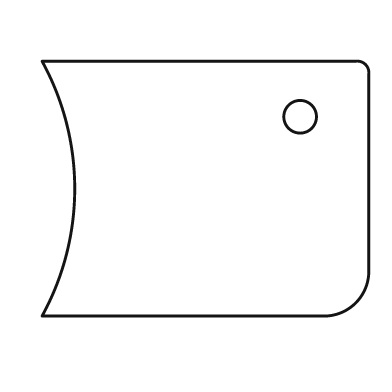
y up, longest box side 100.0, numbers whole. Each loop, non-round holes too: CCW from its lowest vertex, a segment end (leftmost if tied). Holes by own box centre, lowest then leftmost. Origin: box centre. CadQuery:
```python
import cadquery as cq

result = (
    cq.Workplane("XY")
    .moveTo(-50.0, -39.0)
    .lineTo(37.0, -39.0)
    .threePointArc((46.0, -35.0), (50.0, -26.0))
    .lineTo(50.0, 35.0)
    .threePointArc((49.0, 38.0), (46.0, 39.0))
    .lineTo(-50.0, 39.0)
    .threePointArc((-40.0, 0.0), (-50.0, -39.0))
    .close()
    .moveTo(29.0, 22.0)
    .circle(5.0)
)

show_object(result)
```